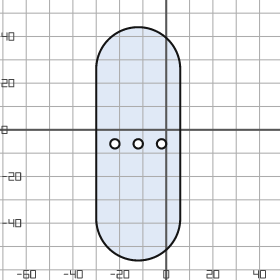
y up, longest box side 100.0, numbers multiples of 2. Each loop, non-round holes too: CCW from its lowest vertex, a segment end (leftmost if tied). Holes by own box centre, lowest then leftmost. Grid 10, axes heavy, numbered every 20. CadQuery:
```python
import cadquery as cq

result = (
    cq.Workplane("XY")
    .moveTo(-30.0, -38.0)
    .threePointArc((-12.0, -56.0), (6.0, -38.0))
    .lineTo(6.0, 26.0)
    .threePointArc((-12.0, 44.0), (-30.0, 26.0))
    .close()
    .moveTo(-22.0, -6.0)
    .circle(2.0)
    .moveTo(-12.0, -6.0)
    .circle(2.0)
    .moveTo(-2.0, -6.0)
    .circle(2.0)
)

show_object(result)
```